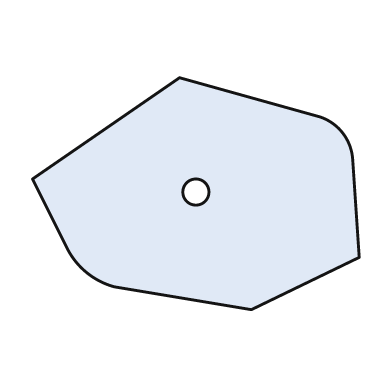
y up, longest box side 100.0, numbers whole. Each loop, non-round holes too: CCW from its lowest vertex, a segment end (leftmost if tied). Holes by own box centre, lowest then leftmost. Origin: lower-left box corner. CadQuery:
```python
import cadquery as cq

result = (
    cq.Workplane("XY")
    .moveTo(67.0, 0.0)
    .lineTo(100.0, 16.0)
    .lineTo(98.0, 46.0)
    .threePointArc((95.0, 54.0), (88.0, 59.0))
    .lineTo(45.0, 71.0)
    .lineTo(0.0, 40.0)
    .lineTo(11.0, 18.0)
    .threePointArc((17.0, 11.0), (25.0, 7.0))
    .close()
    .moveTo(50.0, 36.0)
    .circle(4.0)
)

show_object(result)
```